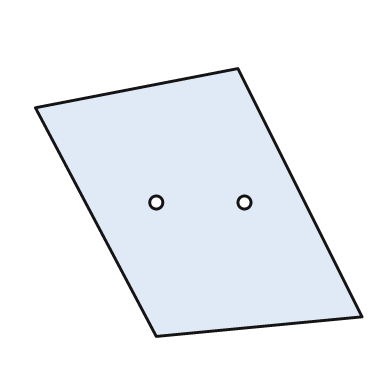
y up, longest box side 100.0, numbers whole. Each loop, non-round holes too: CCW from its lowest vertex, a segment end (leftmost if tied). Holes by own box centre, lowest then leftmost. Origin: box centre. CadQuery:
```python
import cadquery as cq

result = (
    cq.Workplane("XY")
    .moveTo(-13.0, -41.0)
    .lineTo(50.0, -35.0)
    .lineTo(12.0, 41.0)
    .lineTo(-50.0, 29.0)
    .close()
    .moveTo(-13.0, 0.0)
    .circle(2.0)
    .moveTo(14.0, 0.0)
    .circle(2.0)
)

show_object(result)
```